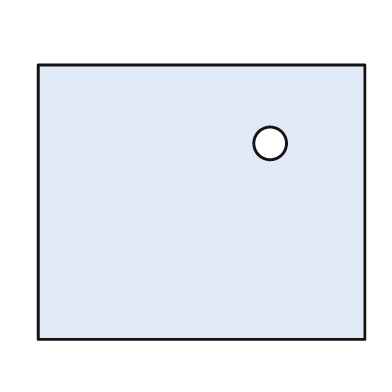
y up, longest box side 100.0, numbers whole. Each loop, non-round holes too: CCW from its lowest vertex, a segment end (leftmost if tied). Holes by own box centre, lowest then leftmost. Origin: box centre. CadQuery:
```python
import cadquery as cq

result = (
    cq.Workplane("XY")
    .moveTo(-50.0, -42.0)
    .lineTo(50.0, -42.0)
    .lineTo(50.0, 42.0)
    .lineTo(-50.0, 42.0)
    .close()
    .moveTo(21.0, 18.0)
    .circle(5.0)
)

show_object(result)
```